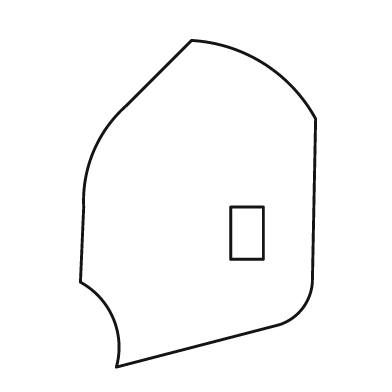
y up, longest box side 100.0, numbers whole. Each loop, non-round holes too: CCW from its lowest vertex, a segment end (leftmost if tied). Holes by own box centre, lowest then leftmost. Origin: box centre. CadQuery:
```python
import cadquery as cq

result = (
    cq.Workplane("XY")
    .moveTo(-25.0, -50.0)
    .lineTo(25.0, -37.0)
    .threePointArc((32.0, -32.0), (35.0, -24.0))
    .lineTo(36.0, 26.0)
    .threePointArc((20.0, 43.0), (-2.0, 50.0))
    .lineTo(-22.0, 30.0)
    .threePointArc((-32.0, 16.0), (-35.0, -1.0))
    .lineTo(-36.0, -24.0)
    .threePointArc((-26.0, -35.0), (-25.0, -50.0))
    .close()
    .moveTo(10.0, -17.0)
    .lineTo(20.0, -17.0)
    .lineTo(20.0, -1.0)
    .lineTo(10.0, -1.0)
    .close()
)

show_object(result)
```